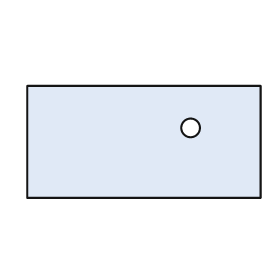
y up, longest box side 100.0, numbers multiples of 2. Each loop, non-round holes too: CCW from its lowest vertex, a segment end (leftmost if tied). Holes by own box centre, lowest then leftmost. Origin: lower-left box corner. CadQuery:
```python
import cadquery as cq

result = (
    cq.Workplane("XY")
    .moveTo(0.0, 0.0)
    .lineTo(100.0, 0.0)
    .lineTo(100.0, 48.0)
    .lineTo(0.0, 48.0)
    .close()
    .moveTo(70.0, 30.0)
    .circle(4.0)
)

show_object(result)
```